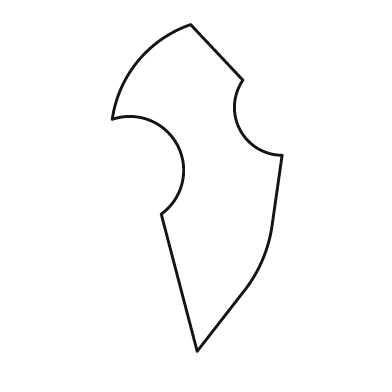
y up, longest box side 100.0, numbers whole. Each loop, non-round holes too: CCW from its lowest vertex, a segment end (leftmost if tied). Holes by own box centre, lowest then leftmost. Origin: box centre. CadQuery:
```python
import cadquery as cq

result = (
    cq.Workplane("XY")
    .moveTo(0.0, -50.0)
    .lineTo(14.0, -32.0)
    .threePointArc((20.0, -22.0), (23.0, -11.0))
    .lineTo(26.0, 10.0)
    .threePointArc((13.0, 18.0), (14.0, 33.0))
    .lineTo(-2.0, 50.0)
    .threePointArc((-18.0, 39.0), (-26.0, 21.0))
    .threePointArc((-6.0, 13.0), (-11.0, -8.0))
    .close()
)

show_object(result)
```